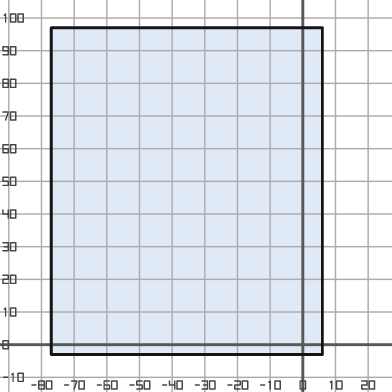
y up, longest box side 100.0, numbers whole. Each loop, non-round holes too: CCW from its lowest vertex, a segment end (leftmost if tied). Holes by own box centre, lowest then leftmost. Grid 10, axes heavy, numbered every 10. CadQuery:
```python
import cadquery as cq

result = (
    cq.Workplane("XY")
    .moveTo(-77.0, -3.0)
    .lineTo(6.0, -3.0)
    .lineTo(6.0, 97.0)
    .lineTo(-77.0, 97.0)
    .close()
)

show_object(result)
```